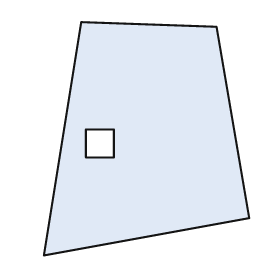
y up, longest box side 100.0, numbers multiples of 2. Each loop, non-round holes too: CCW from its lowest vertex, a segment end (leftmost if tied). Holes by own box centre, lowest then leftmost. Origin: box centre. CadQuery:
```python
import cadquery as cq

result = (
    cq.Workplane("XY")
    .moveTo(-44.0, -50.0)
    .lineTo(44.0, -34.0)
    .lineTo(30.0, 48.0)
    .lineTo(-28.0, 50.0)
    .close()
    .moveTo(-26.0, -8.0)
    .lineTo(-14.0, -8.0)
    .lineTo(-14.0, 4.0)
    .lineTo(-26.0, 4.0)
    .close()
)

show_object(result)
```